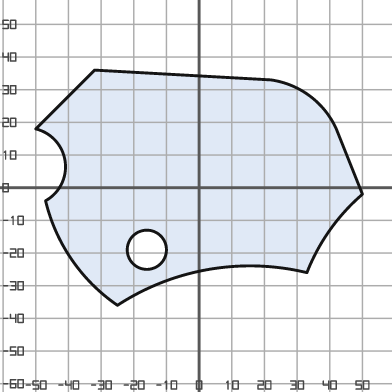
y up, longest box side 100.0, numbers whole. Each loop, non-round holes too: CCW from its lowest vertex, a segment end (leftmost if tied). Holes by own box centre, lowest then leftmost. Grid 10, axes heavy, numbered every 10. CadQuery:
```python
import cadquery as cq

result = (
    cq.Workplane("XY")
    .moveTo(-25.0, -36.0)
    .threePointArc((3.0, -25.0), (33.0, -26.0))
    .threePointArc((40.0, -13.0), (50.0, -2.0))
    .lineTo(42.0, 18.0)
    .threePointArc((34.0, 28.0), (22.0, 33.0))
    .lineTo(-32.0, 36.0)
    .lineTo(-50.0, 18.0)
    .threePointArc((-41.0, 8.0), (-47.0, -4.0))
    .threePointArc((-39.0, -22.0), (-25.0, -36.0))
    .close()
    .moveTo(-16.0, -19.0)
    .circle(6.0)
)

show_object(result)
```